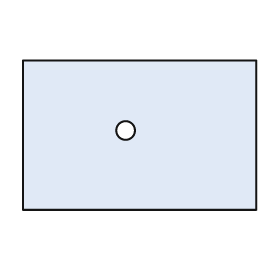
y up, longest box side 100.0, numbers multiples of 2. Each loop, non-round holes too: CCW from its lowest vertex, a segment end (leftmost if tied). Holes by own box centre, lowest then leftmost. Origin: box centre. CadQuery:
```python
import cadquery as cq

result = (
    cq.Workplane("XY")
    .moveTo(-50.0, -32.0)
    .lineTo(50.0, -32.0)
    .lineTo(50.0, 32.0)
    .lineTo(-50.0, 32.0)
    .close()
    .moveTo(-6.0, 2.0)
    .circle(4.0)
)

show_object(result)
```